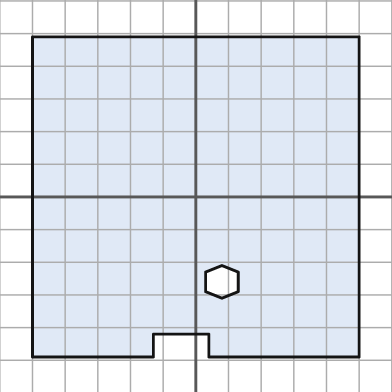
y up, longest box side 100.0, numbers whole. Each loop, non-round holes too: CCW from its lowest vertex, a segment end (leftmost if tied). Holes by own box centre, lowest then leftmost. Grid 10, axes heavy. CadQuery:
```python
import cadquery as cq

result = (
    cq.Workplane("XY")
    .moveTo(-50.0, -49.0)
    .lineTo(-13.0, -49.0)
    .lineTo(-13.0, -42.0)
    .lineTo(4.0, -42.0)
    .lineTo(4.0, -49.0)
    .lineTo(50.0, -49.0)
    .lineTo(50.0, 49.0)
    .lineTo(-50.0, 49.0)
    .close()
    .moveTo(8.0, -31.0)
    .lineTo(13.0, -29.0)
    .lineTo(13.0, -23.0)
    .lineTo(8.0, -21.0)
    .lineTo(3.0, -23.0)
    .lineTo(3.0, -29.0)
    .close()
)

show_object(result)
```